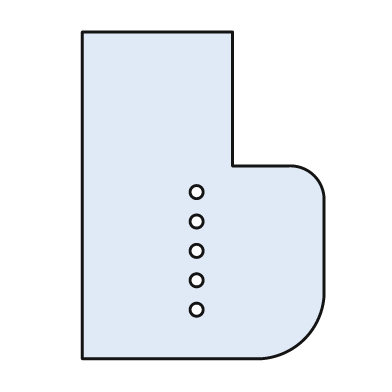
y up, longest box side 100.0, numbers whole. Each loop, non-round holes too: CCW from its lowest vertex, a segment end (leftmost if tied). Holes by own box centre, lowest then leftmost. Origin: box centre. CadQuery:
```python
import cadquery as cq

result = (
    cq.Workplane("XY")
    .moveTo(-37.0, -50.0)
    .lineTo(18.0, -50.0)
    .threePointArc((31.0, -44.0), (37.0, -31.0))
    .lineTo(37.0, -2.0)
    .threePointArc((34.0, 6.0), (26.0, 9.0))
    .lineTo(9.0, 9.0)
    .lineTo(9.0, 50.0)
    .lineTo(-37.0, 50.0)
    .close()
    .moveTo(-2.0, -35.0)
    .circle(2.0)
    .moveTo(-2.0, -26.0)
    .circle(2.0)
    .moveTo(-2.0, -17.0)
    .circle(2.0)
    .moveTo(-2.0, -8.0)
    .circle(2.0)
    .moveTo(-2.0, 1.0)
    .circle(2.0)
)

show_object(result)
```